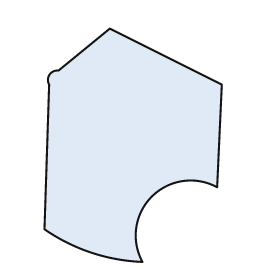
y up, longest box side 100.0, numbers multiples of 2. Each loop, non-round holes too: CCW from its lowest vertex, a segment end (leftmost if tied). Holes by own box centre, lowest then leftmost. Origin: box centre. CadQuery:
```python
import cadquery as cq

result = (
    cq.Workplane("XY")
    .moveTo(4.0, -50.0)
    .threePointArc((8.0, -22.0), (36.0, -18.0))
    .lineTo(38.0, 26.0)
    .lineTo(-10.0, 50.0)
    .lineTo(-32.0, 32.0)
    .threePointArc((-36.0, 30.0), (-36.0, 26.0))
    .lineTo(-38.0, -36.0)
    .threePointArc((-18.0, -46.0), (4.0, -50.0))
    .close()
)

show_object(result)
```